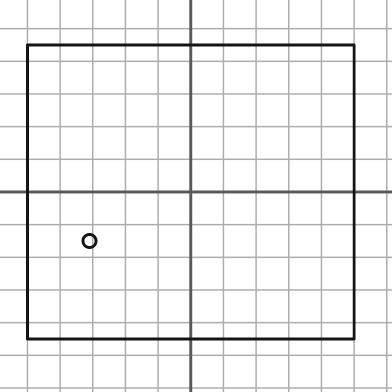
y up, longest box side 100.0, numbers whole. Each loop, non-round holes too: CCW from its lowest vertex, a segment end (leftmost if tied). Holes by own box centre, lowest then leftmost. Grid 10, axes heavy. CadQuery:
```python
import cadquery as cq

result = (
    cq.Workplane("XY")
    .moveTo(-50.0, -45.0)
    .lineTo(50.0, -45.0)
    .lineTo(50.0, 45.0)
    .lineTo(-50.0, 45.0)
    .close()
    .moveTo(-31.0, -15.0)
    .circle(2.0)
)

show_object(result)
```